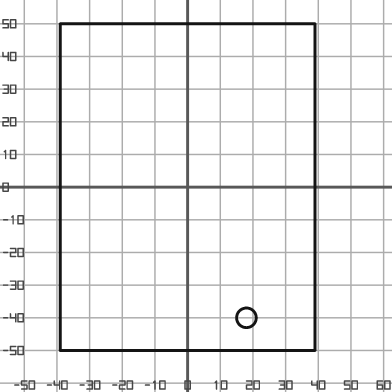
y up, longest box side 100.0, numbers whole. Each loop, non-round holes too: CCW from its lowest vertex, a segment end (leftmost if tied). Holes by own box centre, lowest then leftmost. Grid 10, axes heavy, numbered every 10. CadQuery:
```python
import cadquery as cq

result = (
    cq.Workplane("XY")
    .moveTo(-39.0, -50.0)
    .lineTo(39.0, -50.0)
    .lineTo(39.0, 50.0)
    .lineTo(-39.0, 50.0)
    .close()
    .moveTo(18.0, -40.0)
    .circle(3.0)
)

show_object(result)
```